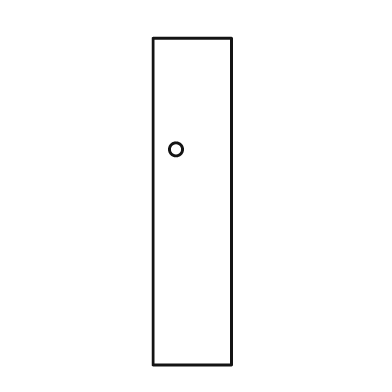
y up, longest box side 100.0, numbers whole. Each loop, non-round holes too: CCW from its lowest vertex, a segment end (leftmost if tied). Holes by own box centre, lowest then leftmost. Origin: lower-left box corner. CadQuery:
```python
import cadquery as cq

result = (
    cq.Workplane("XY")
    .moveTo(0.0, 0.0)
    .lineTo(24.0, 0.0)
    .lineTo(24.0, 100.0)
    .lineTo(0.0, 100.0)
    .close()
    .moveTo(7.0, 66.0)
    .circle(2.0)
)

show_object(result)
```